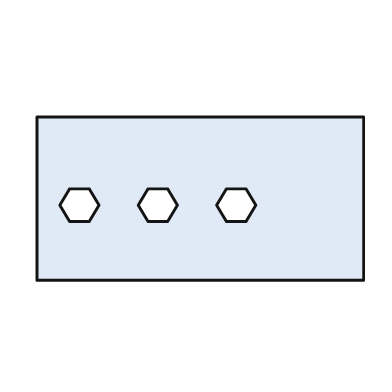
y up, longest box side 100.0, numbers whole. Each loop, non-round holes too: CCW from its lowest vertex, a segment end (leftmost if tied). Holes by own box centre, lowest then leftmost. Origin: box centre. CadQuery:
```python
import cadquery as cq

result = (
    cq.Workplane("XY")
    .moveTo(-50.0, -25.0)
    .lineTo(50.0, -25.0)
    .lineTo(50.0, 25.0)
    .lineTo(-50.0, 25.0)
    .close()
    .moveTo(-40.0, -7.0)
    .lineTo(-34.0, -7.0)
    .lineTo(-31.0, -2.0)
    .lineTo(-34.0, 3.0)
    .lineTo(-40.0, 3.0)
    .lineTo(-43.0, -2.0)
    .close()
    .moveTo(-16.0, -7.0)
    .lineTo(-10.0, -7.0)
    .lineTo(-7.0, -2.0)
    .lineTo(-10.0, 3.0)
    .lineTo(-16.0, 3.0)
    .lineTo(-19.0, -2.0)
    .close()
    .moveTo(8.0, -7.0)
    .lineTo(14.0, -7.0)
    .lineTo(17.0, -2.0)
    .lineTo(14.0, 3.0)
    .lineTo(8.0, 3.0)
    .lineTo(5.0, -2.0)
    .close()
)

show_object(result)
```